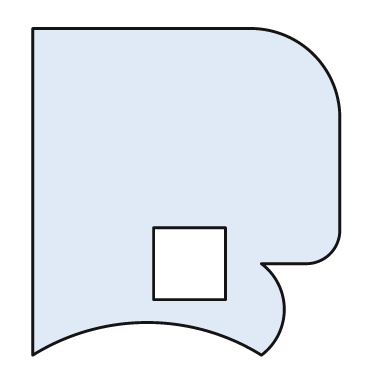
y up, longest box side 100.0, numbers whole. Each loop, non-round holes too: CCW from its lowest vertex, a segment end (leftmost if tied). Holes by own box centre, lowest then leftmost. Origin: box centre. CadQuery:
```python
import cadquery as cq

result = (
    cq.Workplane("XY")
    .moveTo(-47.0, -50.0)
    .threePointArc((-12.0, -40.0), (23.0, -50.0))
    .threePointArc((30.0, -36.0), (23.0, -22.0))
    .lineTo(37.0, -22.0)
    .threePointArc((44.0, -19.0), (47.0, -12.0))
    .lineTo(47.0, 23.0)
    .threePointArc((39.0, 42.0), (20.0, 50.0))
    .lineTo(-47.0, 50.0)
    .close()
    .moveTo(-10.0, -33.0)
    .lineTo(12.0, -33.0)
    .lineTo(12.0, -11.0)
    .lineTo(-10.0, -11.0)
    .close()
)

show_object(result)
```